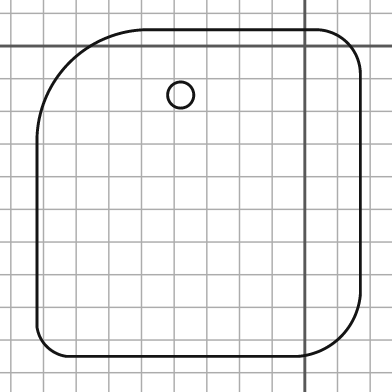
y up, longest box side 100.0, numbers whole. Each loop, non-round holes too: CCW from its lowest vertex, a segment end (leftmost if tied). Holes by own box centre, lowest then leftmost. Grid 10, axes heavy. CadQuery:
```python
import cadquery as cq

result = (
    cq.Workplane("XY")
    .moveTo(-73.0, -95.0)
    .lineTo(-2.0, -95.0)
    .threePointArc((11.0, -89.0), (17.0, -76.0))
    .lineTo(17.0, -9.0)
    .threePointArc((13.0, 1.0), (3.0, 5.0))
    .lineTo(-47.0, 5.0)
    .threePointArc((-72.0, -5.0), (-82.0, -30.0))
    .lineTo(-82.0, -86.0)
    .threePointArc((-79.0, -92.0), (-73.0, -95.0))
    .close()
    .moveTo(-38.0, -15.0)
    .circle(4.0)
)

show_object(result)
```